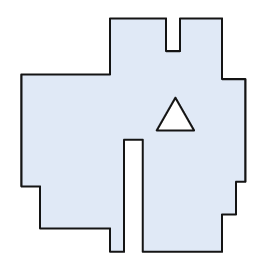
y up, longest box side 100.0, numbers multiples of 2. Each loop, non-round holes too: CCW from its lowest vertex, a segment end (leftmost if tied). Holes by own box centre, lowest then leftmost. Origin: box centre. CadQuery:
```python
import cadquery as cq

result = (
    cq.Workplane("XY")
    .moveTo(-10.0, -50.0)
    .lineTo(-4.0, -50.0)
    .lineTo(-4.0, -2.0)
    .lineTo(4.0, -2.0)
    .lineTo(4.0, -50.0)
    .lineTo(38.0, -50.0)
    .lineTo(38.0, -34.0)
    .lineTo(44.0, -34.0)
    .lineTo(44.0, -20.0)
    .lineTo(48.0, -20.0)
    .lineTo(48.0, 24.0)
    .lineTo(38.0, 24.0)
    .lineTo(38.0, 50.0)
    .lineTo(20.0, 50.0)
    .lineTo(20.0, 36.0)
    .lineTo(14.0, 36.0)
    .lineTo(14.0, 50.0)
    .lineTo(-10.0, 50.0)
    .lineTo(-10.0, 26.0)
    .lineTo(-48.0, 26.0)
    .lineTo(-48.0, -22.0)
    .lineTo(-40.0, -22.0)
    .lineTo(-40.0, -40.0)
    .lineTo(-10.0, -40.0)
    .close()
    .moveTo(10.0, 2.0)
    .lineTo(26.0, 2.0)
    .lineTo(18.0, 16.0)
    .close()
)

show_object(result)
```